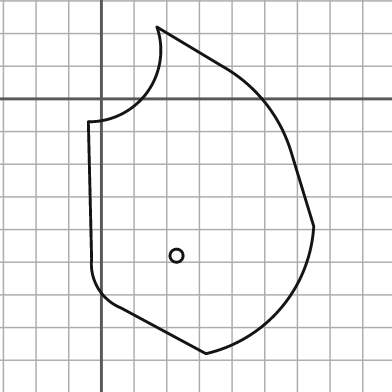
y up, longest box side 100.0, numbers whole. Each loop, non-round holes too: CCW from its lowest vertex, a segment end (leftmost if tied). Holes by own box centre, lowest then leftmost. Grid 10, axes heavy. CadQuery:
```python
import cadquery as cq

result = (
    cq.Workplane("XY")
    .moveTo(32.0, -78.0)
    .threePointArc((55.0, -64.0), (65.0, -39.0))
    .lineTo(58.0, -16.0)
    .threePointArc((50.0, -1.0), (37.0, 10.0))
    .lineTo(17.0, 22.0)
    .threePointArc((14.0, 2.0), (-4.0, -7.0))
    .lineTo(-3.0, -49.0)
    .threePointArc((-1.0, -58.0), (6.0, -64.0))
    .close()
    .moveTo(23.0, -48.0)
    .circle(2.0)
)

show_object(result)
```